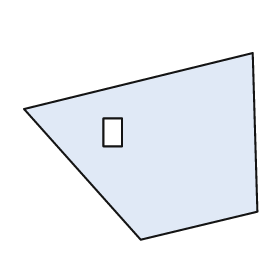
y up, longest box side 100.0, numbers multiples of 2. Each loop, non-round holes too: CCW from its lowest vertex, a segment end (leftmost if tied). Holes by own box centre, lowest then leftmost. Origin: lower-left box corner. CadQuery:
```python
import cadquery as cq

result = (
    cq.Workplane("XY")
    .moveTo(50.0, 0.0)
    .lineTo(100.0, 12.0)
    .lineTo(98.0, 80.0)
    .lineTo(0.0, 56.0)
    .close()
    .moveTo(34.0, 40.0)
    .lineTo(42.0, 40.0)
    .lineTo(42.0, 52.0)
    .lineTo(34.0, 52.0)
    .close()
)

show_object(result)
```